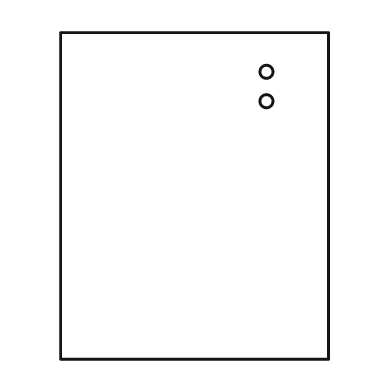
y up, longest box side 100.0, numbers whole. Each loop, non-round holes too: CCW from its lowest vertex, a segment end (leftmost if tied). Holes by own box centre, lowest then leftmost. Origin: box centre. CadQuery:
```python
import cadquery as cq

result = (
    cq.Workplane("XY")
    .moveTo(-41.0, -50.0)
    .lineTo(41.0, -50.0)
    .lineTo(41.0, 50.0)
    .lineTo(-41.0, 50.0)
    .close()
    .moveTo(22.0, 29.0)
    .circle(2.0)
    .moveTo(22.0, 38.0)
    .circle(2.0)
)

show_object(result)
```